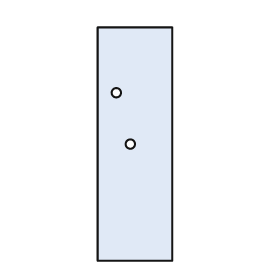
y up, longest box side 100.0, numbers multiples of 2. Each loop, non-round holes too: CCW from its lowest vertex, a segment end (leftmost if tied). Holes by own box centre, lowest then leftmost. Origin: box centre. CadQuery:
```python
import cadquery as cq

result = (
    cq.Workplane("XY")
    .moveTo(-16.0, -50.0)
    .lineTo(16.0, -50.0)
    .lineTo(16.0, 50.0)
    .lineTo(-16.0, 50.0)
    .close()
    .moveTo(-2.0, 0.0)
    .circle(2.0)
    .moveTo(-8.0, 22.0)
    .circle(2.0)
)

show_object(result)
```